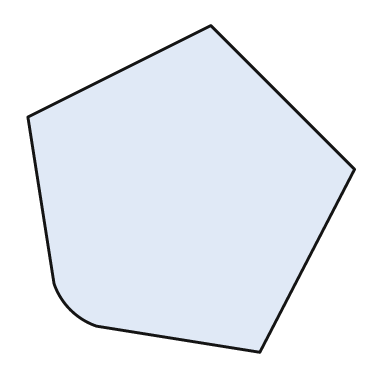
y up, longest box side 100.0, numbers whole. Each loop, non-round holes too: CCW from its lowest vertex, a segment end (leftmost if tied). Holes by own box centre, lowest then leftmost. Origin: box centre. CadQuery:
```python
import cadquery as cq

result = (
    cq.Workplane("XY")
    .moveTo(21.0, -50.0)
    .lineTo(50.0, 6.0)
    .lineTo(6.0, 50.0)
    .lineTo(-50.0, 22.0)
    .lineTo(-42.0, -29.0)
    .threePointArc((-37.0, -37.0), (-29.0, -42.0))
    .close()
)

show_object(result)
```